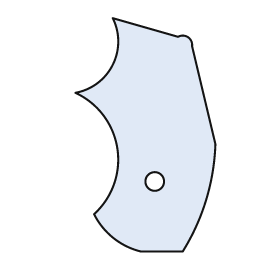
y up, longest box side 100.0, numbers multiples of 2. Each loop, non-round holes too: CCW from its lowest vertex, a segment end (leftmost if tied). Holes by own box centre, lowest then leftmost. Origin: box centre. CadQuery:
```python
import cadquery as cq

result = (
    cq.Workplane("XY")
    .moveTo(-2.0, -50.0)
    .lineTo(16.0, -50.0)
    .threePointArc((26.0, -28.0), (30.0, -4.0))
    .lineTo(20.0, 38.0)
    .threePointArc((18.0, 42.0), (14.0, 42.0))
    .lineTo(-14.0, 50.0)
    .threePointArc((-14.0, 30.0), (-30.0, 18.0))
    .threePointArc((-12.0, -6.0), (-22.0, -34.0))
    .threePointArc((-14.0, -44.0), (-2.0, -50.0))
    .close()
    .moveTo(4.0, -20.0)
    .circle(4.0)
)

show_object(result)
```